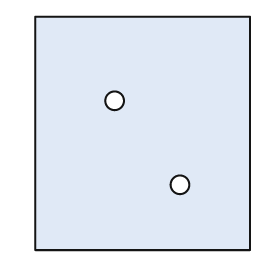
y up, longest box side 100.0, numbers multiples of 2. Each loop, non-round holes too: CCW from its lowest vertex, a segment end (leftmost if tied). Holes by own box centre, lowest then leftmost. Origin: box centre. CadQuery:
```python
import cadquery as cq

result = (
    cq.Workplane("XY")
    .moveTo(-46.0, -50.0)
    .lineTo(46.0, -50.0)
    .lineTo(46.0, 50.0)
    .lineTo(-46.0, 50.0)
    .close()
    .moveTo(16.0, -22.0)
    .circle(4.0)
    .moveTo(-12.0, 14.0)
    .circle(4.0)
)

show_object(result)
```